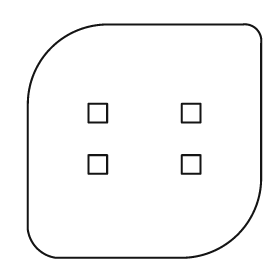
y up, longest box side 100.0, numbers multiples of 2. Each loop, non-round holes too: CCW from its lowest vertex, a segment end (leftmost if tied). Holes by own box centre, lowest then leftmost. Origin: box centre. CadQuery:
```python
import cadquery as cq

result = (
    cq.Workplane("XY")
    .moveTo(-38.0, -50.0)
    .lineTo(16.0, -50.0)
    .threePointArc((40.0, -40.0), (50.0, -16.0))
    .lineTo(50.0, 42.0)
    .threePointArc((48.0, 48.0), (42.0, 50.0))
    .lineTo(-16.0, 50.0)
    .threePointArc((-40.0, 40.0), (-50.0, 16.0))
    .lineTo(-50.0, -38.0)
    .threePointArc((-46.0, -46.0), (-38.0, -50.0))
    .close()
    .moveTo(-24.0, -14.0)
    .lineTo(-16.0, -14.0)
    .lineTo(-16.0, -6.0)
    .lineTo(-24.0, -6.0)
    .close()
    .moveTo(16.0, -14.0)
    .lineTo(24.0, -14.0)
    .lineTo(24.0, -6.0)
    .lineTo(16.0, -6.0)
    .close()
    .moveTo(-24.0, 8.0)
    .lineTo(-16.0, 8.0)
    .lineTo(-16.0, 16.0)
    .lineTo(-24.0, 16.0)
    .close()
    .moveTo(16.0, 8.0)
    .lineTo(24.0, 8.0)
    .lineTo(24.0, 16.0)
    .lineTo(16.0, 16.0)
    .close()
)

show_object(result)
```